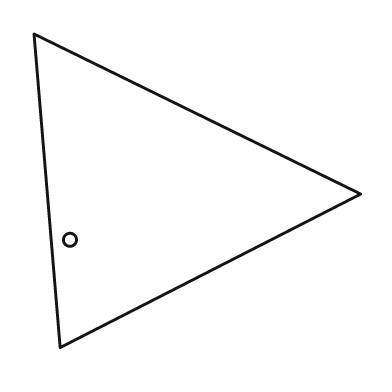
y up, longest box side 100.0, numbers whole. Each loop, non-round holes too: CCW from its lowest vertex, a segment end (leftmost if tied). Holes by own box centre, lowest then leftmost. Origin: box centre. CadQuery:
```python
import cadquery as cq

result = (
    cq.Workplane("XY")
    .moveTo(-42.0, -48.0)
    .lineTo(50.0, -1.0)
    .lineTo(-50.0, 48.0)
    .close()
    .moveTo(-39.0, -15.0)
    .circle(2.0)
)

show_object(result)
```